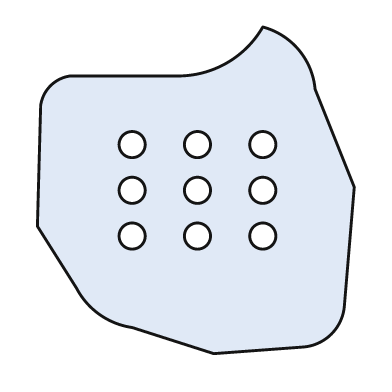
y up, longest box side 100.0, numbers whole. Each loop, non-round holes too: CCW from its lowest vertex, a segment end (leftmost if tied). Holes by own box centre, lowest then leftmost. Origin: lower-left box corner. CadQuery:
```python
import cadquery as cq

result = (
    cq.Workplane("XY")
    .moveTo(54.0, 0.0)
    .lineTo(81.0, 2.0)
    .threePointArc((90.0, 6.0), (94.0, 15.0))
    .lineTo(97.0, 51.0)
    .lineTo(85.0, 81.0)
    .threePointArc((80.0, 93.0), (69.0, 100.0))
    .threePointArc((58.0, 89.0), (43.0, 85.0))
    .lineTo(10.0, 85.0)
    .threePointArc((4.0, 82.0), (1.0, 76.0))
    .lineTo(0.0, 39.0)
    .lineTo(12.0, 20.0)
    .threePointArc((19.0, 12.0), (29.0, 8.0))
    .close()
    .moveTo(29.0, 36.0)
    .circle(4.0)
    .moveTo(49.0, 36.0)
    .circle(4.0)
    .moveTo(69.0, 36.0)
    .circle(4.0)
    .moveTo(29.0, 50.0)
    .circle(4.0)
    .moveTo(49.0, 50.0)
    .circle(4.0)
    .moveTo(69.0, 50.0)
    .circle(4.0)
    .moveTo(29.0, 64.0)
    .circle(4.0)
    .moveTo(49.0, 64.0)
    .circle(4.0)
    .moveTo(69.0, 64.0)
    .circle(4.0)
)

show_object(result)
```